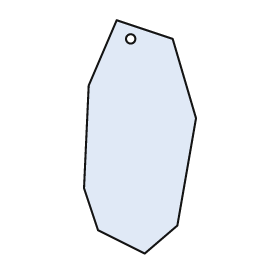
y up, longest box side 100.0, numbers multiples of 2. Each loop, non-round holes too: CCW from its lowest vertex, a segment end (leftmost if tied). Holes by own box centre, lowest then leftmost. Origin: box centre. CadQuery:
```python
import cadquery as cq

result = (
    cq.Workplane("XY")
    .moveTo(2.0, -50.0)
    .lineTo(16.0, -38.0)
    .lineTo(24.0, 8.0)
    .lineTo(14.0, 42.0)
    .lineTo(-10.0, 50.0)
    .lineTo(-22.0, 22.0)
    .lineTo(-24.0, -22.0)
    .lineTo(-18.0, -40.0)
    .close()
    .moveTo(-4.0, 42.0)
    .circle(2.0)
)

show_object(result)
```